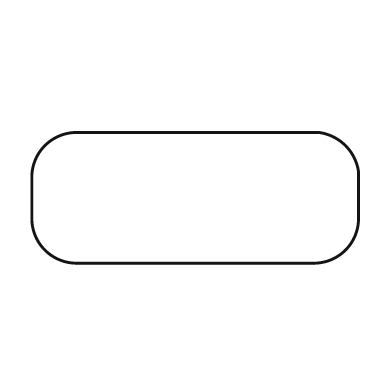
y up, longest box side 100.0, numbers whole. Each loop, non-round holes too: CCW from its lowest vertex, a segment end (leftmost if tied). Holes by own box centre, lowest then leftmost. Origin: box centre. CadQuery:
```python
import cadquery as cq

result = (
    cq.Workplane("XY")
    .moveTo(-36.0, -20.0)
    .lineTo(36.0, -20.0)
    .threePointArc((46.0, -16.0), (50.0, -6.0))
    .lineTo(50.0, 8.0)
    .threePointArc((46.0, 16.0), (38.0, 20.0))
    .lineTo(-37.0, 20.0)
    .threePointArc((-46.0, 16.0), (-50.0, 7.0))
    .lineTo(-50.0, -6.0)
    .threePointArc((-46.0, -16.0), (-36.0, -20.0))
    .close()
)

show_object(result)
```